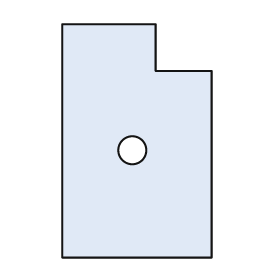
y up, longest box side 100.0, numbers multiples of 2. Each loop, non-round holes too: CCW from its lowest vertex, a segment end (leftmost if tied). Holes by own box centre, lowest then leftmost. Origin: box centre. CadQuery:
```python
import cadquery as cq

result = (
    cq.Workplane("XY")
    .moveTo(-32.0, -50.0)
    .lineTo(32.0, -50.0)
    .lineTo(32.0, 30.0)
    .lineTo(8.0, 30.0)
    .lineTo(8.0, 50.0)
    .lineTo(-32.0, 50.0)
    .close()
    .moveTo(-2.0, -4.0)
    .circle(6.0)
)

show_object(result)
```